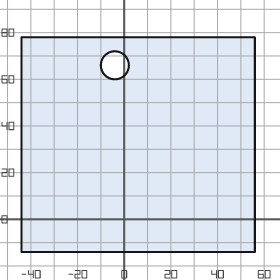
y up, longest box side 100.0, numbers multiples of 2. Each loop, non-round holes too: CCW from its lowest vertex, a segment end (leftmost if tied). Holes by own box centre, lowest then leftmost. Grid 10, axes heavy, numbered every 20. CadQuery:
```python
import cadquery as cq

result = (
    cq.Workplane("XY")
    .moveTo(-44.0, -14.0)
    .lineTo(56.0, -14.0)
    .lineTo(56.0, 78.0)
    .lineTo(-44.0, 78.0)
    .close()
    .moveTo(-4.0, 66.0)
    .circle(6.0)
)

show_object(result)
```